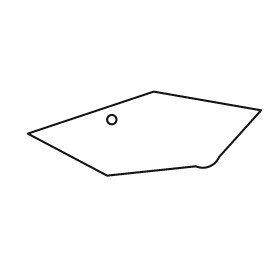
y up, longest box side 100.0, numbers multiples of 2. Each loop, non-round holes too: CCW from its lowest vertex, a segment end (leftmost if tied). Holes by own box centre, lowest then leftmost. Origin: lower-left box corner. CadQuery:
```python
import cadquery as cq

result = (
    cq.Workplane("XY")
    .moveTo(34.0, 0.0)
    .lineTo(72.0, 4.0)
    .threePointArc((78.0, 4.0), (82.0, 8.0))
    .lineTo(100.0, 28.0)
    .lineTo(54.0, 36.0)
    .lineTo(0.0, 18.0)
    .close()
    .moveTo(36.0, 24.0)
    .circle(2.0)
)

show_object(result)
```